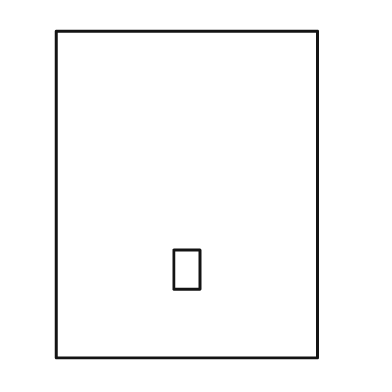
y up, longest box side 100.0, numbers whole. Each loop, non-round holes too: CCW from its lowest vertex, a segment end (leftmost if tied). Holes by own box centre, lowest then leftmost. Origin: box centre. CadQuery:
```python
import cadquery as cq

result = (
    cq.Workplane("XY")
    .moveTo(-40.0, -50.0)
    .lineTo(40.0, -50.0)
    .lineTo(40.0, 50.0)
    .lineTo(-40.0, 50.0)
    .close()
    .moveTo(-4.0, -29.0)
    .lineTo(4.0, -29.0)
    .lineTo(4.0, -17.0)
    .lineTo(-4.0, -17.0)
    .close()
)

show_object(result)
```